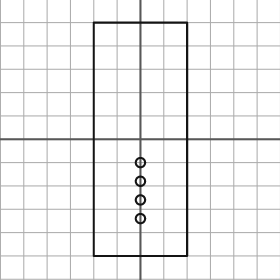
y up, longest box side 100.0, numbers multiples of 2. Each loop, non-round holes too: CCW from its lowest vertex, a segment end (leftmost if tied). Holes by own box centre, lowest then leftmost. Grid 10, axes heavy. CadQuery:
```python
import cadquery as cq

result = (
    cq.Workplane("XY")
    .moveTo(-20.0, -50.0)
    .lineTo(20.0, -50.0)
    .lineTo(20.0, 50.0)
    .lineTo(-20.0, 50.0)
    .close()
    .moveTo(0.0, -34.0)
    .circle(2.0)
    .moveTo(0.0, -26.0)
    .circle(2.0)
    .moveTo(0.0, -18.0)
    .circle(2.0)
    .moveTo(0.0, -10.0)
    .circle(2.0)
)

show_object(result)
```